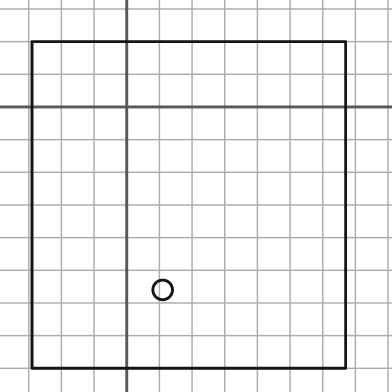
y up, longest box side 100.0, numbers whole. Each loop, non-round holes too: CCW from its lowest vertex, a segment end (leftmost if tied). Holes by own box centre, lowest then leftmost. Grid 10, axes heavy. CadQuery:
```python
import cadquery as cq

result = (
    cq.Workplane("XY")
    .moveTo(-29.0, -80.0)
    .lineTo(67.0, -80.0)
    .lineTo(67.0, 20.0)
    .lineTo(-29.0, 20.0)
    .close()
    .moveTo(11.0, -56.0)
    .circle(3.0)
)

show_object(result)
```